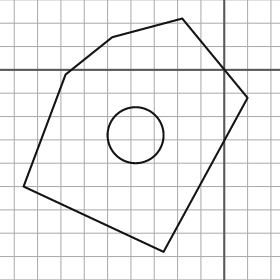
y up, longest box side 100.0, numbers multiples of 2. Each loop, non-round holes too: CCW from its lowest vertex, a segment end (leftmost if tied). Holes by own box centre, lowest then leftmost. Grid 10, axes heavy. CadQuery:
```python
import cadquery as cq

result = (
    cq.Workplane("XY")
    .moveTo(-26.0, -78.0)
    .lineTo(10.0, -12.0)
    .lineTo(-18.0, 22.0)
    .lineTo(-48.0, 14.0)
    .lineTo(-68.0, -2.0)
    .lineTo(-86.0, -50.0)
    .close()
    .moveTo(-38.0, -28.0)
    .circle(12.0)
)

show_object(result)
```